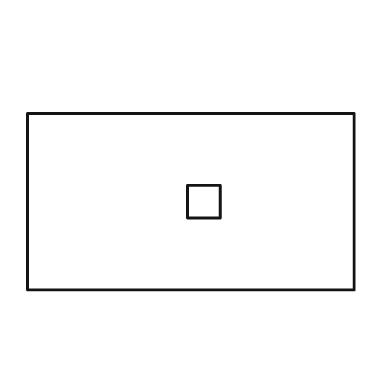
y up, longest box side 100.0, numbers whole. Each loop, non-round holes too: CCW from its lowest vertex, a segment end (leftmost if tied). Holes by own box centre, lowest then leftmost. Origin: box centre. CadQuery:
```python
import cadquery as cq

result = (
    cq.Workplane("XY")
    .moveTo(-50.0, -27.0)
    .lineTo(50.0, -27.0)
    .lineTo(50.0, 27.0)
    .lineTo(-50.0, 27.0)
    .close()
    .moveTo(-1.0, -5.0)
    .lineTo(9.0, -5.0)
    .lineTo(9.0, 5.0)
    .lineTo(-1.0, 5.0)
    .close()
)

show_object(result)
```